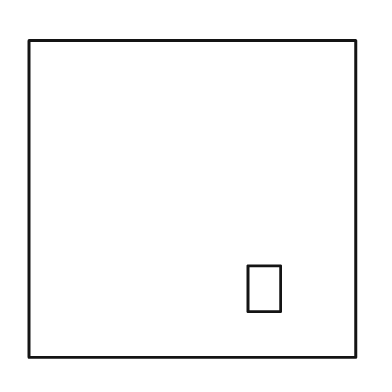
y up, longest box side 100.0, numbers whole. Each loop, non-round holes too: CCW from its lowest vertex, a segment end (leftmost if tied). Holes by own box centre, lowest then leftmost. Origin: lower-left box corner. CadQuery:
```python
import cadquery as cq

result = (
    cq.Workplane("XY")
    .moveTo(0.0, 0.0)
    .lineTo(100.0, 0.0)
    .lineTo(100.0, 97.0)
    .lineTo(0.0, 97.0)
    .close()
    .moveTo(67.0, 14.0)
    .lineTo(77.0, 14.0)
    .lineTo(77.0, 28.0)
    .lineTo(67.0, 28.0)
    .close()
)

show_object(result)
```